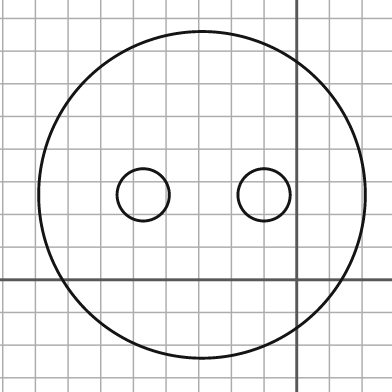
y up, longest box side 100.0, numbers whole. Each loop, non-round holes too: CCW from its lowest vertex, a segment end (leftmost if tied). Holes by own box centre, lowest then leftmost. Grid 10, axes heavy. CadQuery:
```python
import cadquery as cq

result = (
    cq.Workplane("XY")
    .moveTo(-29.0, 26.0)
    .circle(50.0)
    .moveTo(-47.0, 26.0)
    .circle(8.0)
    .moveTo(-10.0, 26.0)
    .circle(8.0)
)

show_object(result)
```